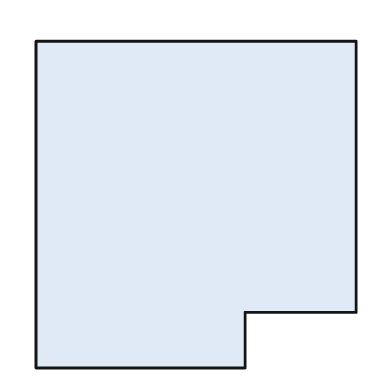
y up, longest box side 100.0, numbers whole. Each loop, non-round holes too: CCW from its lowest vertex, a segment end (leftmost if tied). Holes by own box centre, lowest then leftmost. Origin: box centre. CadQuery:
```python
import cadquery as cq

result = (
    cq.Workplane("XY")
    .moveTo(-49.0, -50.0)
    .lineTo(15.0, -50.0)
    .lineTo(15.0, -33.0)
    .lineTo(49.0, -33.0)
    .lineTo(49.0, 50.0)
    .lineTo(-49.0, 50.0)
    .close()
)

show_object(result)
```